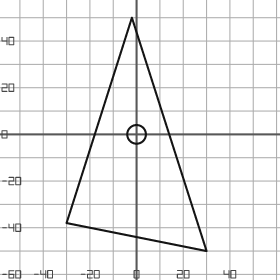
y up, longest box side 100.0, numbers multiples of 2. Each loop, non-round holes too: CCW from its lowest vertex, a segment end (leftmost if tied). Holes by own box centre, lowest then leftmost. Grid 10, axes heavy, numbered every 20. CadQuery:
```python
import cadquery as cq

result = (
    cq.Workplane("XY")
    .moveTo(30.0, -50.0)
    .lineTo(-2.0, 50.0)
    .lineTo(-30.0, -38.0)
    .close()
    .moveTo(0.0, 0.0)
    .circle(4.0)
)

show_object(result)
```